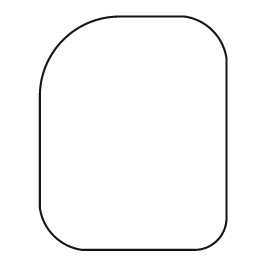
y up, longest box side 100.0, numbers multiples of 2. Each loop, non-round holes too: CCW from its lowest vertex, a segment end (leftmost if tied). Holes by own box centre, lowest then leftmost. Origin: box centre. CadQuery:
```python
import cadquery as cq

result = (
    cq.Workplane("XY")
    .moveTo(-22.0, -50.0)
    .lineTo(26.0, -50.0)
    .threePointArc((36.0, -46.0), (40.0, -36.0))
    .lineTo(40.0, 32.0)
    .threePointArc((34.0, 44.0), (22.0, 50.0))
    .lineTo(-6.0, 50.0)
    .threePointArc((-30.0, 40.0), (-40.0, 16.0))
    .lineTo(-40.0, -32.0)
    .threePointArc((-34.0, -44.0), (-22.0, -50.0))
    .close()
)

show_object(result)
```